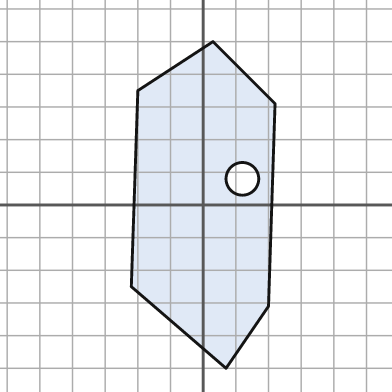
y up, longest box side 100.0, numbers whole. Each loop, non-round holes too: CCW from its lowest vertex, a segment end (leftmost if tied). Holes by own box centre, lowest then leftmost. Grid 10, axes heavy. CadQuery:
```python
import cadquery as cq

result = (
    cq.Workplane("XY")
    .moveTo(7.0, -50.0)
    .lineTo(20.0, -31.0)
    .lineTo(22.0, 31.0)
    .lineTo(3.0, 50.0)
    .lineTo(-20.0, 35.0)
    .lineTo(-22.0, -25.0)
    .close()
    .moveTo(12.0, 8.0)
    .circle(5.0)
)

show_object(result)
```